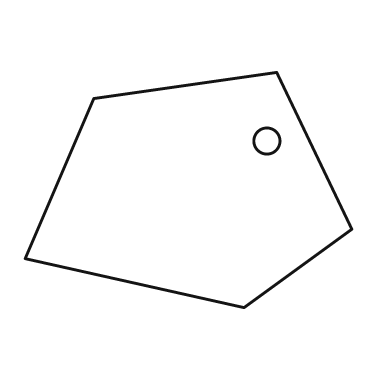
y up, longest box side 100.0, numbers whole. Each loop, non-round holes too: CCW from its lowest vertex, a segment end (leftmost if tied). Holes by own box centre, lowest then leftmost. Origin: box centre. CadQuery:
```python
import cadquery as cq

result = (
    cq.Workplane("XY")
    .moveTo(17.0, -36.0)
    .lineTo(50.0, -12.0)
    .lineTo(27.0, 36.0)
    .lineTo(-29.0, 28.0)
    .lineTo(-50.0, -21.0)
    .close()
    .moveTo(24.0, 15.0)
    .circle(4.0)
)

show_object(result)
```